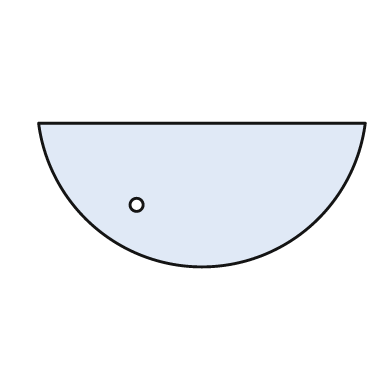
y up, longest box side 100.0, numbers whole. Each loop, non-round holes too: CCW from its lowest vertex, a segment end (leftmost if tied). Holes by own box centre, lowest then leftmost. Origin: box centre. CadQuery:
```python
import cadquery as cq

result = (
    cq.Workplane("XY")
    .moveTo(-50.0, 22.0)
    .threePointArc((0.0, -22.0), (50.0, 22.0))
    .close()
    .moveTo(-20.0, -3.0)
    .circle(2.0)
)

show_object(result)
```